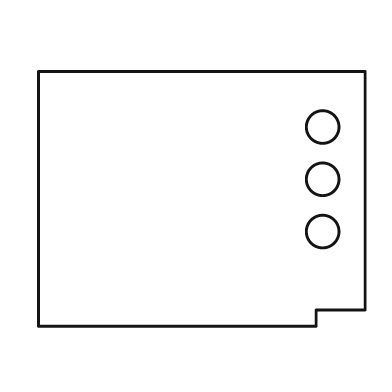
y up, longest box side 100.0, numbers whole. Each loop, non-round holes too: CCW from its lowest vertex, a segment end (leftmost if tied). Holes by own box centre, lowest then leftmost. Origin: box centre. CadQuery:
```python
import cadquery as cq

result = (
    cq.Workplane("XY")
    .moveTo(-50.0, -39.0)
    .lineTo(35.0, -39.0)
    .lineTo(35.0, -34.0)
    .lineTo(50.0, -34.0)
    .lineTo(50.0, 39.0)
    .lineTo(-50.0, 39.0)
    .close()
    .moveTo(37.0, -10.0)
    .circle(5.0)
    .moveTo(37.0, 6.0)
    .circle(5.0)
    .moveTo(37.0, 22.0)
    .circle(5.0)
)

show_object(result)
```